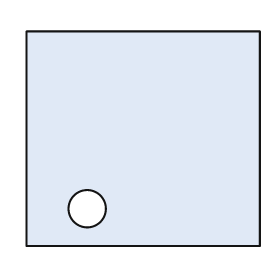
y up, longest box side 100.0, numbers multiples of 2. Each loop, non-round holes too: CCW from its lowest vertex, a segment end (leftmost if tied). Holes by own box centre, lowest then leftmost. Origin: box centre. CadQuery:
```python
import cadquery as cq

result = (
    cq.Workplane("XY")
    .moveTo(-50.0, -46.0)
    .lineTo(50.0, -46.0)
    .lineTo(50.0, 46.0)
    .lineTo(-50.0, 46.0)
    .close()
    .moveTo(-24.0, -30.0)
    .circle(8.0)
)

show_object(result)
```